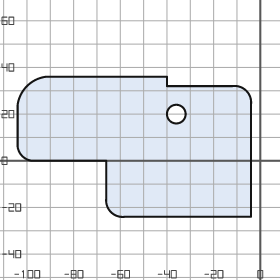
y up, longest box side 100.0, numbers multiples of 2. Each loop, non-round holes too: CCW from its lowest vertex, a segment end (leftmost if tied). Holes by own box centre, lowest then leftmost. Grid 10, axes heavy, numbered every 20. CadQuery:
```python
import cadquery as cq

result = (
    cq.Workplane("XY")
    .moveTo(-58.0, -24.0)
    .lineTo(-4.0, -24.0)
    .lineTo(-4.0, 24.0)
    .threePointArc((-6.0, 30.0), (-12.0, 32.0))
    .lineTo(-40.0, 32.0)
    .lineTo(-40.0, 36.0)
    .lineTo(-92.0, 36.0)
    .threePointArc((-100.0, 32.0), (-104.0, 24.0))
    .lineTo(-104.0, 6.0)
    .threePointArc((-102.0, 2.0), (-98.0, 0.0))
    .lineTo(-66.0, 0.0)
    .lineTo(-66.0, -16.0)
    .threePointArc((-64.0, -22.0), (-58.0, -24.0))
    .close()
    .moveTo(-36.0, 20.0)
    .circle(4.0)
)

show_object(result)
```